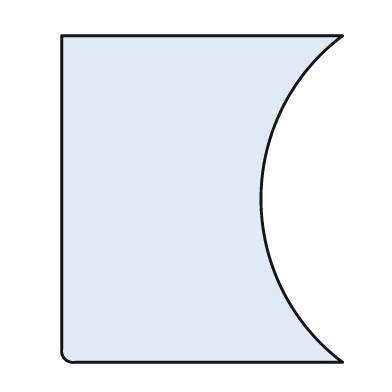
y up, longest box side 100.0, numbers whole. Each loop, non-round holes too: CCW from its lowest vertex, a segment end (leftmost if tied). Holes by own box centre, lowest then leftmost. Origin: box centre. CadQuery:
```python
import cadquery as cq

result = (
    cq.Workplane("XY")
    .moveTo(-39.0, -50.0)
    .lineTo(43.0, -50.0)
    .threePointArc((18.0, 0.0), (43.0, 50.0))
    .lineTo(-43.0, 50.0)
    .lineTo(-43.0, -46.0)
    .threePointArc((-42.0, -49.0), (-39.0, -50.0))
    .close()
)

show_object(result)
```